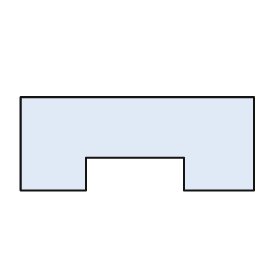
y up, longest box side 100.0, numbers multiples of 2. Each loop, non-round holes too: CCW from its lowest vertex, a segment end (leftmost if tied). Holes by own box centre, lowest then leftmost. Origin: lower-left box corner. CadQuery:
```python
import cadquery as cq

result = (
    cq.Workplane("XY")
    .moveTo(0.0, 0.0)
    .lineTo(28.0, 0.0)
    .lineTo(28.0, 14.0)
    .lineTo(70.0, 14.0)
    .lineTo(70.0, 0.0)
    .lineTo(100.0, 0.0)
    .lineTo(100.0, 40.0)
    .lineTo(0.0, 40.0)
    .close()
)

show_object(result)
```